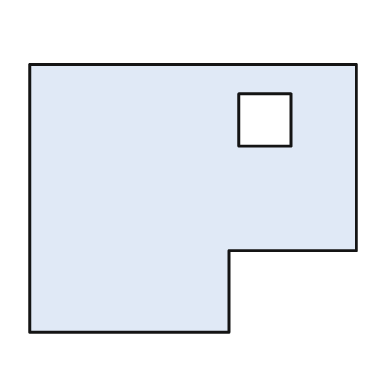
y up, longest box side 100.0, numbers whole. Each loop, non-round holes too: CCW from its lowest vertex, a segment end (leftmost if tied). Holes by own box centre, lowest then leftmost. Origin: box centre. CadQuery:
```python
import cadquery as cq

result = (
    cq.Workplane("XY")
    .moveTo(-50.0, -41.0)
    .lineTo(11.0, -41.0)
    .lineTo(11.0, -16.0)
    .lineTo(50.0, -16.0)
    .lineTo(50.0, 41.0)
    .lineTo(-50.0, 41.0)
    .close()
    .moveTo(14.0, 16.0)
    .lineTo(30.0, 16.0)
    .lineTo(30.0, 32.0)
    .lineTo(14.0, 32.0)
    .close()
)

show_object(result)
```